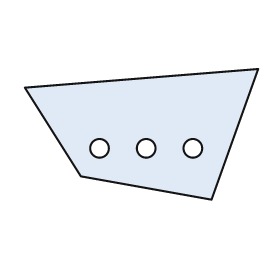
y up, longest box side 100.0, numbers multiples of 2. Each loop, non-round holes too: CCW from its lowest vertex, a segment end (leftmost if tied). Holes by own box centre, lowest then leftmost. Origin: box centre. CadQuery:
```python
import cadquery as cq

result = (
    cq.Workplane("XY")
    .moveTo(30.0, -28.0)
    .lineTo(50.0, 28.0)
    .lineTo(-50.0, 20.0)
    .lineTo(-26.0, -18.0)
    .close()
    .moveTo(-18.0, -6.0)
    .circle(4.0)
    .moveTo(2.0, -6.0)
    .circle(4.0)
    .moveTo(22.0, -6.0)
    .circle(4.0)
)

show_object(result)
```